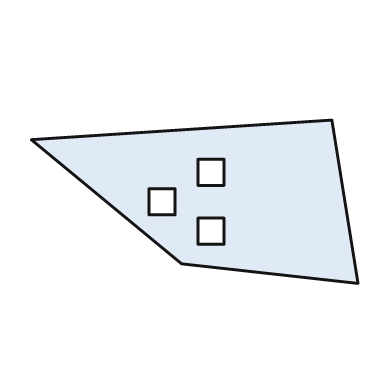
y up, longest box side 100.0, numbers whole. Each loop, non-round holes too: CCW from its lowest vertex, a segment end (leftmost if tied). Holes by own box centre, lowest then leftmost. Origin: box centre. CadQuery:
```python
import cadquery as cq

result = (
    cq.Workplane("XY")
    .moveTo(50.0, -25.0)
    .lineTo(42.0, 25.0)
    .lineTo(-50.0, 19.0)
    .lineTo(-4.0, -19.0)
    .close()
    .moveTo(1.0, -13.0)
    .lineTo(9.0, -13.0)
    .lineTo(9.0, -5.0)
    .lineTo(1.0, -5.0)
    .close()
    .moveTo(-14.0, -4.0)
    .lineTo(-6.0, -4.0)
    .lineTo(-6.0, 4.0)
    .lineTo(-14.0, 4.0)
    .close()
    .moveTo(1.0, 5.0)
    .lineTo(9.0, 5.0)
    .lineTo(9.0, 13.0)
    .lineTo(1.0, 13.0)
    .close()
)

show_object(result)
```